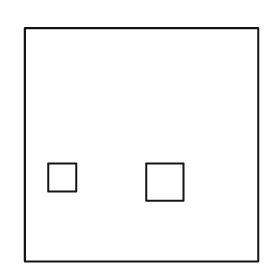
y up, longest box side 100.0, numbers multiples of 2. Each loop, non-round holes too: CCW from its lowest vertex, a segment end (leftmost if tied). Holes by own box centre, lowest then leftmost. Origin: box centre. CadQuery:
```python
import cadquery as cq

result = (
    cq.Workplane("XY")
    .moveTo(-50.0, -50.0)
    .lineTo(50.0, -50.0)
    .lineTo(50.0, 50.0)
    .lineTo(-50.0, 50.0)
    .close()
    .moveTo(2.0, -24.0)
    .lineTo(18.0, -24.0)
    .lineTo(18.0, -8.0)
    .lineTo(2.0, -8.0)
    .close()
    .moveTo(-40.0, -20.0)
    .lineTo(-28.0, -20.0)
    .lineTo(-28.0, -8.0)
    .lineTo(-40.0, -8.0)
    .close()
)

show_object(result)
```